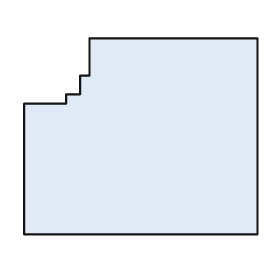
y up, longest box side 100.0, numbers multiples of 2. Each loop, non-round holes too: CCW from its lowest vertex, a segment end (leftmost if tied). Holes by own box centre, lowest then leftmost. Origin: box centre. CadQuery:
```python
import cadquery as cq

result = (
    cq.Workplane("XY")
    .moveTo(-50.0, -42.0)
    .lineTo(50.0, -42.0)
    .lineTo(50.0, 42.0)
    .lineTo(-22.0, 42.0)
    .lineTo(-22.0, 26.0)
    .lineTo(-26.0, 26.0)
    .lineTo(-26.0, 18.0)
    .lineTo(-32.0, 18.0)
    .lineTo(-32.0, 14.0)
    .lineTo(-50.0, 14.0)
    .close()
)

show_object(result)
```